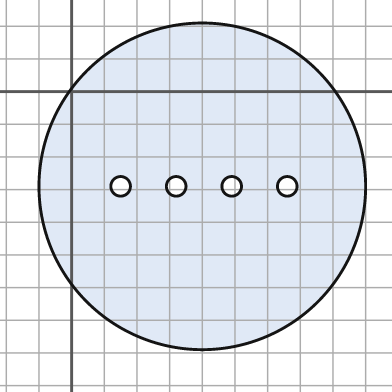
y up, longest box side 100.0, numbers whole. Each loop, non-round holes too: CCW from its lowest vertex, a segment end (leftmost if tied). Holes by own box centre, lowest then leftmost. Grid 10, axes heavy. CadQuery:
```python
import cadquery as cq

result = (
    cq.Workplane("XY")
    .moveTo(40.0, -29.0)
    .circle(50.0)
    .moveTo(15.0, -29.0)
    .circle(3.0)
    .moveTo(32.0, -29.0)
    .circle(3.0)
    .moveTo(49.0, -29.0)
    .circle(3.0)
    .moveTo(66.0, -29.0)
    .circle(3.0)
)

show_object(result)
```